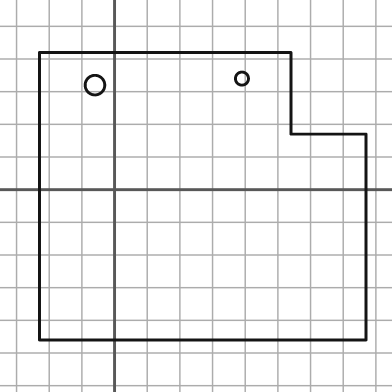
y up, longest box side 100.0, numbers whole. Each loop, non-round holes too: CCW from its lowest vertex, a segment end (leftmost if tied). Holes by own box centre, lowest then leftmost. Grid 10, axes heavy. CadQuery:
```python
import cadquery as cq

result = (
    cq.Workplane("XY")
    .moveTo(-23.0, -46.0)
    .lineTo(77.0, -46.0)
    .lineTo(77.0, 17.0)
    .lineTo(54.0, 17.0)
    .lineTo(54.0, 42.0)
    .lineTo(-23.0, 42.0)
    .close()
    .moveTo(-6.0, 32.0)
    .circle(3.0)
    .moveTo(39.0, 34.0)
    .circle(2.0)
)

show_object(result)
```